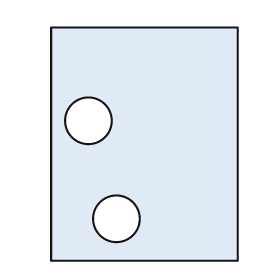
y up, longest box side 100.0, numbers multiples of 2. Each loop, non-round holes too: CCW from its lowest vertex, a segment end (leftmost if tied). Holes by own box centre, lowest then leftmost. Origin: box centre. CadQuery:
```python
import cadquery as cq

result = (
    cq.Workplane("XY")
    .moveTo(-40.0, -50.0)
    .lineTo(40.0, -50.0)
    .lineTo(40.0, 50.0)
    .lineTo(-40.0, 50.0)
    .close()
    .moveTo(-12.0, -32.0)
    .circle(10.0)
    .moveTo(-24.0, 10.0)
    .circle(10.0)
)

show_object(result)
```